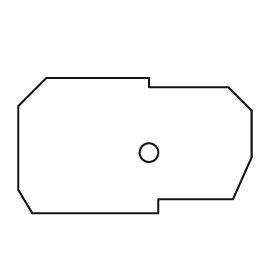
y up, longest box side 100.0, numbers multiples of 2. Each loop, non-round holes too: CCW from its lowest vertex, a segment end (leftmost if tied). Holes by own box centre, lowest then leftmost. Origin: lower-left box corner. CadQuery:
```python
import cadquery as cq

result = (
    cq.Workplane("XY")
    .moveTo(6.0, 0.0)
    .lineTo(60.0, 0.0)
    .lineTo(60.0, 6.0)
    .lineTo(92.0, 6.0)
    .lineTo(100.0, 24.0)
    .lineTo(100.0, 44.0)
    .lineTo(90.0, 54.0)
    .lineTo(56.0, 54.0)
    .lineTo(56.0, 58.0)
    .lineTo(12.0, 58.0)
    .lineTo(0.0, 46.0)
    .lineTo(0.0, 10.0)
    .close()
    .moveTo(56.0, 26.0)
    .circle(4.0)
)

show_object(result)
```